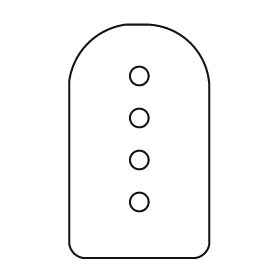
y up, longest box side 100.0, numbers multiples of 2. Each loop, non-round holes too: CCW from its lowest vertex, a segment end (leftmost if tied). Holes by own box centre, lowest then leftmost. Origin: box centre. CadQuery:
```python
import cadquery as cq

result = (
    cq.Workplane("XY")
    .moveTo(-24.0, -50.0)
    .lineTo(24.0, -50.0)
    .threePointArc((28.0, -48.0), (30.0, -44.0))
    .lineTo(30.0, 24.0)
    .threePointArc((22.0, 42.0), (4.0, 50.0))
    .lineTo(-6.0, 50.0)
    .threePointArc((-22.0, 42.0), (-30.0, 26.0))
    .lineTo(-30.0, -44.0)
    .threePointArc((-28.0, -48.0), (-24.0, -50.0))
    .close()
    .moveTo(0.0, -26.0)
    .circle(4.0)
    .moveTo(0.0, -8.0)
    .circle(4.0)
    .moveTo(0.0, 10.0)
    .circle(4.0)
    .moveTo(0.0, 28.0)
    .circle(4.0)
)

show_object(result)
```